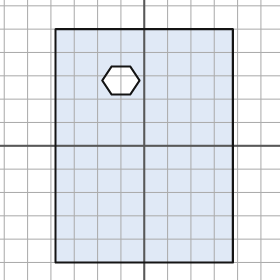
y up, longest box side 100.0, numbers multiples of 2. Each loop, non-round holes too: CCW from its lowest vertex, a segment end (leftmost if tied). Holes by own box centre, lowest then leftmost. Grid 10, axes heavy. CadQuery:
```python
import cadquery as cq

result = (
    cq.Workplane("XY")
    .moveTo(-38.0, -50.0)
    .lineTo(38.0, -50.0)
    .lineTo(38.0, 50.0)
    .lineTo(-38.0, 50.0)
    .close()
    .moveTo(-14.0, 22.0)
    .lineTo(-6.0, 22.0)
    .lineTo(-2.0, 28.0)
    .lineTo(-6.0, 34.0)
    .lineTo(-14.0, 34.0)
    .lineTo(-18.0, 28.0)
    .close()
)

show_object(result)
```